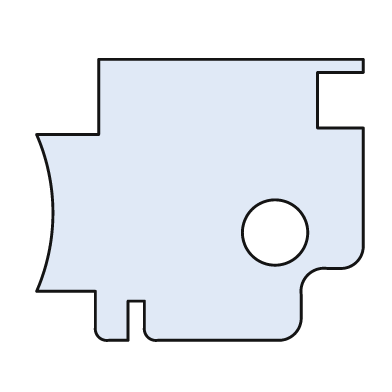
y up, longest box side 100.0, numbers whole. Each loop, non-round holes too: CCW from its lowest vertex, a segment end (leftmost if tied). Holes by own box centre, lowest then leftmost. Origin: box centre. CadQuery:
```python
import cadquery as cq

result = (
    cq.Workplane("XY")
    .moveTo(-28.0, -43.0)
    .lineTo(-22.0, -43.0)
    .lineTo(-22.0, -31.0)
    .lineTo(-17.0, -31.0)
    .lineTo(-17.0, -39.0)
    .threePointArc((-16.0, -42.0), (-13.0, -43.0))
    .lineTo(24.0, -43.0)
    .threePointArc((29.0, -41.0), (31.0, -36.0))
    .lineTo(31.0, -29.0)
    .threePointArc((33.0, -23.0), (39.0, -21.0))
    .lineTo(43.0, -21.0)
    .threePointArc((48.0, -19.0), (50.0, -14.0))
    .lineTo(50.0, 22.0)
    .lineTo(36.0, 22.0)
    .lineTo(36.0, 39.0)
    .lineTo(50.0, 39.0)
    .lineTo(50.0, 43.0)
    .lineTo(-31.0, 43.0)
    .lineTo(-31.0, 20.0)
    .lineTo(-50.0, 20.0)
    .threePointArc((-45.0, -4.0), (-50.0, -28.0))
    .lineTo(-32.0, -28.0)
    .lineTo(-32.0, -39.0)
    .threePointArc((-31.0, -42.0), (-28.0, -43.0))
    .close()
    .moveTo(23.0, -10.0)
    .circle(10.0)
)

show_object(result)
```